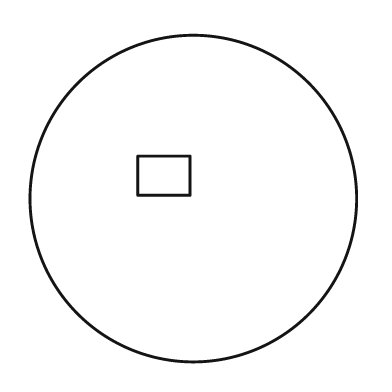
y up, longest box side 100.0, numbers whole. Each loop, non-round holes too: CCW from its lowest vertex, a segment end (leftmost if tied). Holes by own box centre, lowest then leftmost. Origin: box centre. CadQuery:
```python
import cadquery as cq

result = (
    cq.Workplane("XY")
    .moveTo(0.0, 0.0)
    .circle(50.0)
    .moveTo(-17.0, 1.0)
    .lineTo(-1.0, 1.0)
    .lineTo(-1.0, 13.0)
    .lineTo(-17.0, 13.0)
    .close()
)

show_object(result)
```